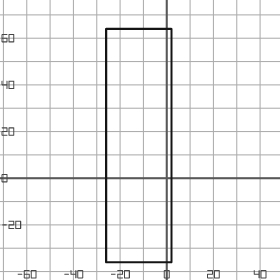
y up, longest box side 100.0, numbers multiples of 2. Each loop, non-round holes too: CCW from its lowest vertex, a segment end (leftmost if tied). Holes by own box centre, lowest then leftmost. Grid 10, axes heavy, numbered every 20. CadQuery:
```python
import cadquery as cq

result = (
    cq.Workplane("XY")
    .moveTo(-26.0, -36.0)
    .lineTo(2.0, -36.0)
    .lineTo(2.0, 64.0)
    .lineTo(-26.0, 64.0)
    .close()
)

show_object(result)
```